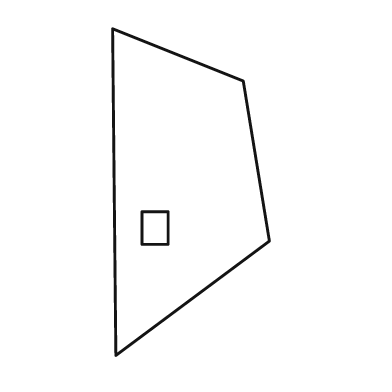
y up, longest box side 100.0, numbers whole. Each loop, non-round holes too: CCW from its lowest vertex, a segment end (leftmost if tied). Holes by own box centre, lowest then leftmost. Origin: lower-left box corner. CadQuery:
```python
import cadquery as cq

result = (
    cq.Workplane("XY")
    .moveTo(1.0, 0.0)
    .lineTo(48.0, 35.0)
    .lineTo(40.0, 84.0)
    .lineTo(0.0, 100.0)
    .close()
    .moveTo(9.0, 34.0)
    .lineTo(17.0, 34.0)
    .lineTo(17.0, 44.0)
    .lineTo(9.0, 44.0)
    .close()
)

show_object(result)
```